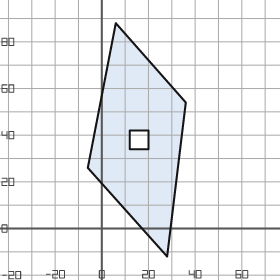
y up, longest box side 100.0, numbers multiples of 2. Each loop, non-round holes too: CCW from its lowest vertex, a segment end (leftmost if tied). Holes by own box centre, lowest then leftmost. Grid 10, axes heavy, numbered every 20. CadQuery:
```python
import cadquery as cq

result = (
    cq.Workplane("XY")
    .moveTo(28.0, -12.0)
    .lineTo(36.0, 54.0)
    .lineTo(6.0, 88.0)
    .lineTo(-6.0, 26.0)
    .close()
    .moveTo(12.0, 34.0)
    .lineTo(20.0, 34.0)
    .lineTo(20.0, 42.0)
    .lineTo(12.0, 42.0)
    .close()
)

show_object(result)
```